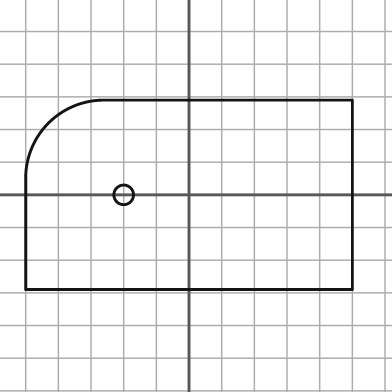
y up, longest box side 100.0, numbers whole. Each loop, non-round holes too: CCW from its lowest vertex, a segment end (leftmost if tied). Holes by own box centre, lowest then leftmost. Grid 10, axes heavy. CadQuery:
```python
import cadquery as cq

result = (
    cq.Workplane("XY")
    .moveTo(-50.0, -29.0)
    .lineTo(50.0, -29.0)
    .lineTo(50.0, 29.0)
    .lineTo(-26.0, 29.0)
    .threePointArc((-43.0, 22.0), (-50.0, 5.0))
    .close()
    .moveTo(-20.0, 0.0)
    .circle(3.0)
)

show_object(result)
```